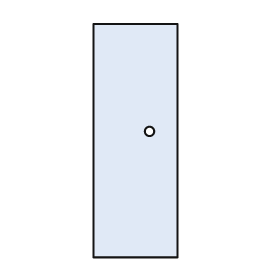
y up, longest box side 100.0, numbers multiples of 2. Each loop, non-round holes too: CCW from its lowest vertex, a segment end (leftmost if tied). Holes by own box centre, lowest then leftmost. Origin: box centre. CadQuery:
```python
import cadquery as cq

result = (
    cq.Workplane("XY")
    .moveTo(-18.0, -50.0)
    .lineTo(18.0, -50.0)
    .lineTo(18.0, 50.0)
    .lineTo(-18.0, 50.0)
    .close()
    .moveTo(6.0, 4.0)
    .circle(2.0)
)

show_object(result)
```